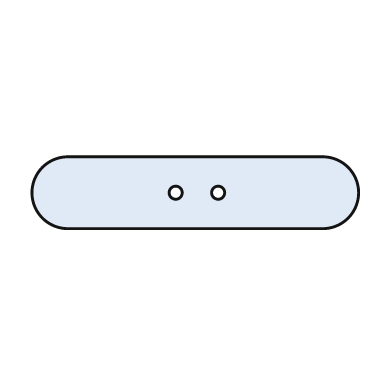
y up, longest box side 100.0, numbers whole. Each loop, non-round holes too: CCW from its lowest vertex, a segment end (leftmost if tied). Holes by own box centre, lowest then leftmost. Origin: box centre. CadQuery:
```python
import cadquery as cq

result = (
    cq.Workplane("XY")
    .moveTo(-39.0, -11.0)
    .lineTo(39.0, -11.0)
    .threePointArc((50.0, 0.0), (39.0, 11.0))
    .lineTo(-39.0, 11.0)
    .threePointArc((-50.0, 0.0), (-39.0, -11.0))
    .close()
    .moveTo(-6.0, 0.0)
    .circle(2.0)
    .moveTo(7.0, 0.0)
    .circle(2.0)
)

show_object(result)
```